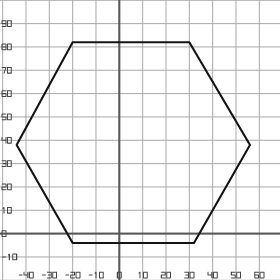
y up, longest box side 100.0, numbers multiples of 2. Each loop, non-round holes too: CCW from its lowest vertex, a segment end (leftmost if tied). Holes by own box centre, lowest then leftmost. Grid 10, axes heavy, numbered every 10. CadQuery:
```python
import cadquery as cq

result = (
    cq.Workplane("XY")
    .moveTo(-20.0, -4.0)
    .lineTo(32.0, -4.0)
    .lineTo(56.0, 38.0)
    .lineTo(30.0, 82.0)
    .lineTo(-20.0, 82.0)
    .lineTo(-44.0, 38.0)
    .close()
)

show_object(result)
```